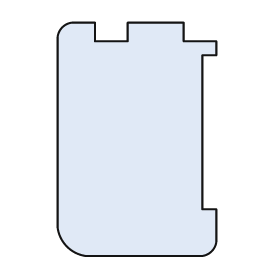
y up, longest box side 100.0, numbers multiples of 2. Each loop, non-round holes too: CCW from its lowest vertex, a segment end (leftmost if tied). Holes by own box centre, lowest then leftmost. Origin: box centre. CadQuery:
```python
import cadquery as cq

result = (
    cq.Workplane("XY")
    .moveTo(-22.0, -50.0)
    .lineTo(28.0, -50.0)
    .threePointArc((32.0, -48.0), (34.0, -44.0))
    .lineTo(34.0, -30.0)
    .lineTo(28.0, -30.0)
    .lineTo(28.0, 36.0)
    .lineTo(34.0, 36.0)
    .lineTo(34.0, 42.0)
    .lineTo(20.0, 42.0)
    .lineTo(20.0, 50.0)
    .lineTo(-4.0, 50.0)
    .lineTo(-4.0, 42.0)
    .lineTo(-18.0, 42.0)
    .lineTo(-18.0, 50.0)
    .lineTo(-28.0, 50.0)
    .threePointArc((-32.0, 48.0), (-34.0, 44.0))
    .lineTo(-34.0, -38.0)
    .threePointArc((-30.0, -46.0), (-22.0, -50.0))
    .close()
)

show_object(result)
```